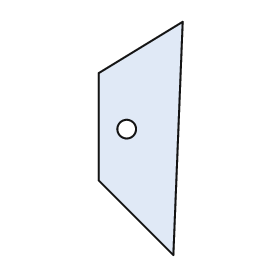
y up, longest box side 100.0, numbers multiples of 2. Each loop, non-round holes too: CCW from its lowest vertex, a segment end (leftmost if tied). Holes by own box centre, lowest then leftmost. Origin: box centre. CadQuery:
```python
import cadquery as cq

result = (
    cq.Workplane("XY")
    .moveTo(14.0, -50.0)
    .lineTo(18.0, 50.0)
    .lineTo(-18.0, 28.0)
    .lineTo(-18.0, -18.0)
    .close()
    .moveTo(-6.0, 4.0)
    .circle(4.0)
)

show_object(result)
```